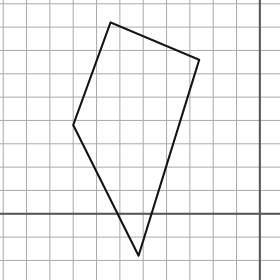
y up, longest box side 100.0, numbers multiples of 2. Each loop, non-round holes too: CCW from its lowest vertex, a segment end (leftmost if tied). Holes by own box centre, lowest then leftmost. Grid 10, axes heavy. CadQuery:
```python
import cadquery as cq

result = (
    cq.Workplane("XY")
    .moveTo(-52.0, -18.0)
    .lineTo(-26.0, 66.0)
    .lineTo(-64.0, 82.0)
    .lineTo(-80.0, 38.0)
    .close()
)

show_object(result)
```